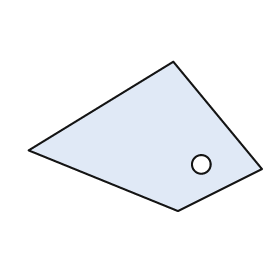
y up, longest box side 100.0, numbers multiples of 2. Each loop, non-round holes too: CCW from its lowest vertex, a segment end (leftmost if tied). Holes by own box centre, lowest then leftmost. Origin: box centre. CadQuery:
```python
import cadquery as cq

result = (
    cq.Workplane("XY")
    .moveTo(14.0, -32.0)
    .lineTo(50.0, -14.0)
    .lineTo(12.0, 32.0)
    .lineTo(-50.0, -6.0)
    .close()
    .moveTo(24.0, -12.0)
    .circle(4.0)
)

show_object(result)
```